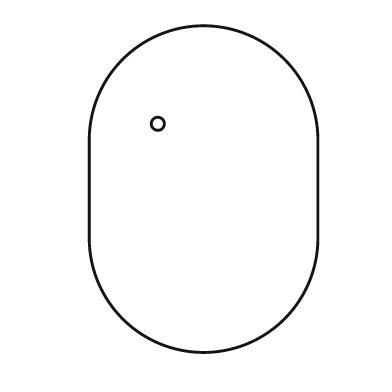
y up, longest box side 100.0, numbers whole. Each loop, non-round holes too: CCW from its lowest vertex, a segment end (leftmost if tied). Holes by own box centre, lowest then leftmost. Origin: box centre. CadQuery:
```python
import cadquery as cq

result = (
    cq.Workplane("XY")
    .moveTo(-35.0, -15.0)
    .threePointArc((0.0, -50.0), (35.0, -15.0))
    .lineTo(35.0, 15.0)
    .threePointArc((0.0, 50.0), (-35.0, 15.0))
    .close()
    .moveTo(-14.0, 20.0)
    .circle(2.0)
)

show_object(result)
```